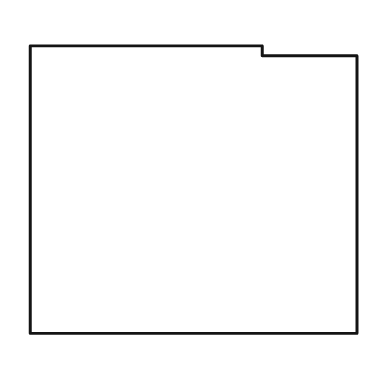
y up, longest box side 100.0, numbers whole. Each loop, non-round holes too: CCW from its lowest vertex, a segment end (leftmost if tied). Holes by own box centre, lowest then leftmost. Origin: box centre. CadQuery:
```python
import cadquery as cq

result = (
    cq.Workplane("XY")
    .moveTo(-50.0, -44.0)
    .lineTo(50.0, -44.0)
    .lineTo(50.0, 41.0)
    .lineTo(21.0, 41.0)
    .lineTo(21.0, 44.0)
    .lineTo(-50.0, 44.0)
    .close()
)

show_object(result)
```